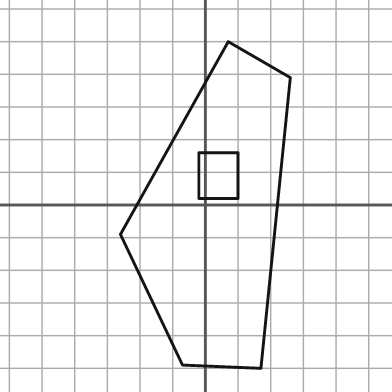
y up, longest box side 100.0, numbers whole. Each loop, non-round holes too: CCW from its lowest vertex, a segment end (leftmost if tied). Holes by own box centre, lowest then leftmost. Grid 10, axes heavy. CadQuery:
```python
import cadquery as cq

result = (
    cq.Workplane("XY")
    .moveTo(17.0, -50.0)
    .lineTo(26.0, 39.0)
    .lineTo(7.0, 50.0)
    .lineTo(-26.0, -9.0)
    .lineTo(-7.0, -49.0)
    .close()
    .moveTo(-2.0, 2.0)
    .lineTo(10.0, 2.0)
    .lineTo(10.0, 16.0)
    .lineTo(-2.0, 16.0)
    .close()
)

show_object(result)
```